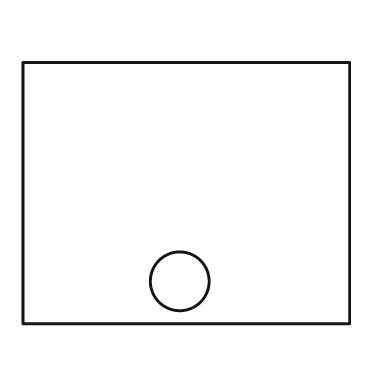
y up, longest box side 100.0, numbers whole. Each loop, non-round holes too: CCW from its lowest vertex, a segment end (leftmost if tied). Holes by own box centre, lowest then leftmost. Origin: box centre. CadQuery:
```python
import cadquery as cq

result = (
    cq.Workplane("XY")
    .moveTo(-50.0, -40.0)
    .lineTo(50.0, -40.0)
    .lineTo(50.0, 40.0)
    .lineTo(-50.0, 40.0)
    .close()
    .moveTo(-2.0, -27.0)
    .circle(9.0)
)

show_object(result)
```